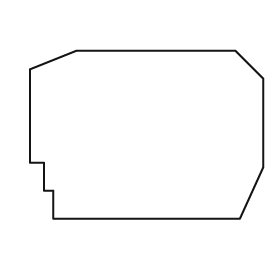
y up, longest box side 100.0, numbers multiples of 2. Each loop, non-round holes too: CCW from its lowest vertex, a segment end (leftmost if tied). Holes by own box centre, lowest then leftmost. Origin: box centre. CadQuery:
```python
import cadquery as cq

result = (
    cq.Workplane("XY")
    .moveTo(-40.0, -36.0)
    .lineTo(40.0, -36.0)
    .lineTo(50.0, -14.0)
    .lineTo(50.0, 24.0)
    .lineTo(38.0, 36.0)
    .lineTo(-30.0, 36.0)
    .lineTo(-50.0, 28.0)
    .lineTo(-50.0, -12.0)
    .lineTo(-44.0, -12.0)
    .lineTo(-44.0, -24.0)
    .lineTo(-40.0, -24.0)
    .close()
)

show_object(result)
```